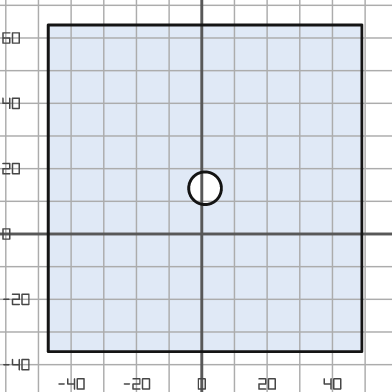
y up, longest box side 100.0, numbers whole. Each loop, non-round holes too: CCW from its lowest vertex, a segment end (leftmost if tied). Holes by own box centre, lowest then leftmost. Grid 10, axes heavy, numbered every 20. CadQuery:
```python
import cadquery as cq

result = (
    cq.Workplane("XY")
    .moveTo(-47.0, -36.0)
    .lineTo(49.0, -36.0)
    .lineTo(49.0, 64.0)
    .lineTo(-47.0, 64.0)
    .close()
    .moveTo(1.0, 14.0)
    .circle(5.0)
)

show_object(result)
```